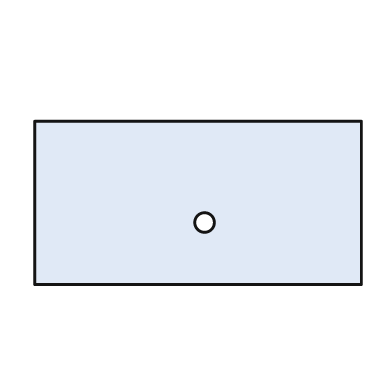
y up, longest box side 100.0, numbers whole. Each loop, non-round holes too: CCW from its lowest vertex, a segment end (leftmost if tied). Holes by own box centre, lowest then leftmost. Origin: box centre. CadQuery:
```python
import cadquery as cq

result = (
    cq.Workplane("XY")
    .moveTo(-50.0, -25.0)
    .lineTo(50.0, -25.0)
    .lineTo(50.0, 25.0)
    .lineTo(-50.0, 25.0)
    .close()
    .moveTo(2.0, -6.0)
    .circle(3.0)
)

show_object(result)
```